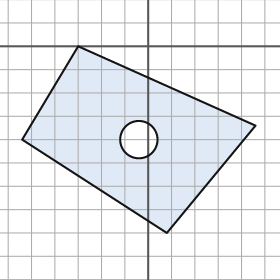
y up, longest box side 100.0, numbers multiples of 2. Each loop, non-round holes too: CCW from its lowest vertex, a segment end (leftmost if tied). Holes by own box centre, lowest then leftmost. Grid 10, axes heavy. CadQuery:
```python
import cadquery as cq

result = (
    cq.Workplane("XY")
    .moveTo(8.0, -80.0)
    .lineTo(46.0, -34.0)
    .lineTo(-30.0, 0.0)
    .lineTo(-54.0, -40.0)
    .close()
    .moveTo(-4.0, -40.0)
    .circle(8.0)
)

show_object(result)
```